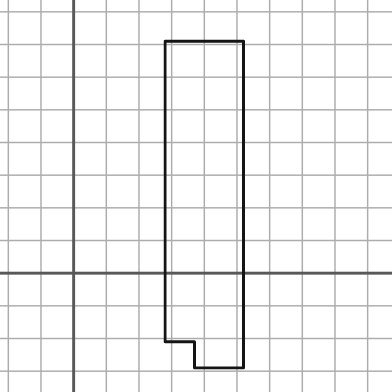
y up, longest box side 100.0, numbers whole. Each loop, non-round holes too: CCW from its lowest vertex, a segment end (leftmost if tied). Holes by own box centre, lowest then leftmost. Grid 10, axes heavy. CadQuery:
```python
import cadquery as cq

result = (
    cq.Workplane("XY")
    .moveTo(37.0, -29.0)
    .lineTo(52.0, -29.0)
    .lineTo(52.0, 71.0)
    .lineTo(28.0, 71.0)
    .lineTo(28.0, -21.0)
    .lineTo(37.0, -21.0)
    .close()
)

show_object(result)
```